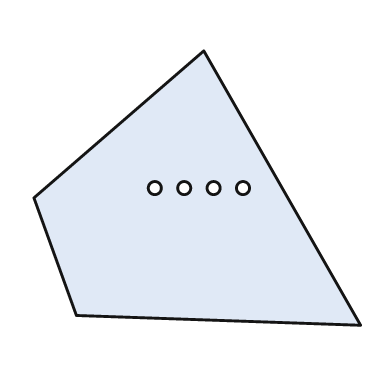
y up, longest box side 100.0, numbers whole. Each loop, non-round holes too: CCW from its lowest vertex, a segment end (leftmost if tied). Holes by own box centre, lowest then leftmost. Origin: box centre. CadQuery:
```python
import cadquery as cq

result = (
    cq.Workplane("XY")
    .moveTo(50.0, -42.0)
    .lineTo(2.0, 42.0)
    .lineTo(-50.0, -3.0)
    .lineTo(-37.0, -39.0)
    .close()
    .moveTo(-13.0, 0.0)
    .circle(2.0)
    .moveTo(-4.0, 0.0)
    .circle(2.0)
    .moveTo(5.0, 0.0)
    .circle(2.0)
    .moveTo(14.0, 0.0)
    .circle(2.0)
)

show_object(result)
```